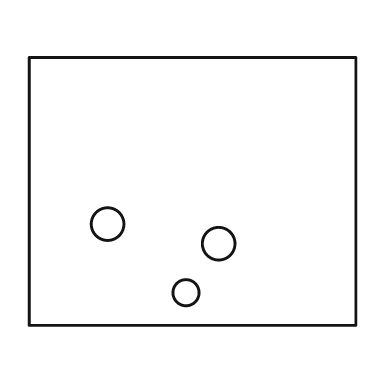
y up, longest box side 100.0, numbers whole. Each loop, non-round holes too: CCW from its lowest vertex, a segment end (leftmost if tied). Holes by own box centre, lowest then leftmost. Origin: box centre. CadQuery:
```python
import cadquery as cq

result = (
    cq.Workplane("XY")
    .moveTo(-50.0, -41.0)
    .lineTo(50.0, -41.0)
    .lineTo(50.0, 41.0)
    .lineTo(-50.0, 41.0)
    .close()
    .moveTo(-2.0, -31.0)
    .circle(4.0)
    .moveTo(8.0, -16.0)
    .circle(5.0)
    .moveTo(-26.0, -10.0)
    .circle(5.0)
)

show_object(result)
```